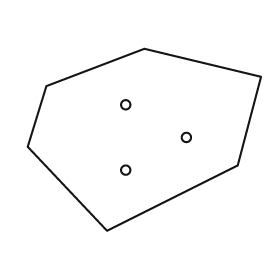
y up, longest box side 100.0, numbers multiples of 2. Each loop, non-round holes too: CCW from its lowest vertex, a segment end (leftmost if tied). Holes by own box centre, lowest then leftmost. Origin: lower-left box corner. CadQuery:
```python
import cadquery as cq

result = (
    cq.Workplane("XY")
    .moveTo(34.0, 0.0)
    .lineTo(90.0, 28.0)
    .lineTo(100.0, 66.0)
    .lineTo(50.0, 78.0)
    .lineTo(8.0, 62.0)
    .lineTo(0.0, 36.0)
    .close()
    .moveTo(42.0, 26.0)
    .circle(2.0)
    .moveTo(68.0, 40.0)
    .circle(2.0)
    .moveTo(42.0, 54.0)
    .circle(2.0)
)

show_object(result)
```